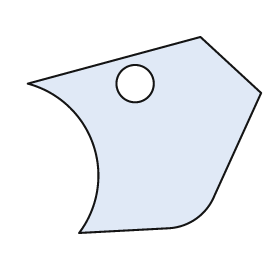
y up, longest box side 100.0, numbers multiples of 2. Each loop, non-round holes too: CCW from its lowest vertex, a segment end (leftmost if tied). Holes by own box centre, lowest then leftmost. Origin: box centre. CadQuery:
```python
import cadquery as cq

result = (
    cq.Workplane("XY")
    .moveTo(-28.0, -42.0)
    .lineTo(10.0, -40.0)
    .threePointArc((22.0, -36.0), (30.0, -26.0))
    .lineTo(50.0, 18.0)
    .lineTo(24.0, 42.0)
    .lineTo(-50.0, 22.0)
    .threePointArc((-22.0, -4.0), (-28.0, -42.0))
    .close()
    .moveTo(-4.0, 22.0)
    .circle(8.0)
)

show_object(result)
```